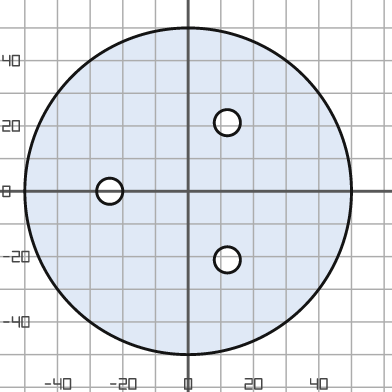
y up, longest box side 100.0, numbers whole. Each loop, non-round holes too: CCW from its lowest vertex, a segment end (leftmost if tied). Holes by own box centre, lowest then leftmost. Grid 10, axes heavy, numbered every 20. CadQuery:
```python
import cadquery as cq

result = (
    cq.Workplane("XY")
    .moveTo(0.0, 0.0)
    .circle(50.0)
    .moveTo(12.0, -21.0)
    .circle(4.0)
    .moveTo(-24.0, 0.0)
    .circle(4.0)
    .moveTo(12.0, 21.0)
    .circle(4.0)
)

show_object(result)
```